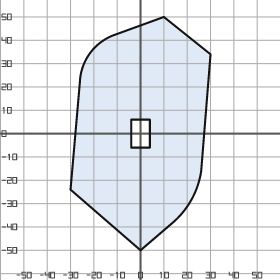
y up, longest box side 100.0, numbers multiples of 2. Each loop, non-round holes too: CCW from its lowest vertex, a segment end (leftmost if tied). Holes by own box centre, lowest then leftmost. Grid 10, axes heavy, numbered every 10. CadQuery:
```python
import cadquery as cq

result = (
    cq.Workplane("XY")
    .moveTo(0.0, -50.0)
    .lineTo(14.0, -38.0)
    .threePointArc((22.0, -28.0), (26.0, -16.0))
    .lineTo(30.0, 34.0)
    .lineTo(10.0, 50.0)
    .lineTo(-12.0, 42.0)
    .threePointArc((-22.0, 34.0), (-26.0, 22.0))
    .lineTo(-30.0, -24.0)
    .close()
    .moveTo(-4.0, -6.0)
    .lineTo(4.0, -6.0)
    .lineTo(4.0, 6.0)
    .lineTo(-4.0, 6.0)
    .close()
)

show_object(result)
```